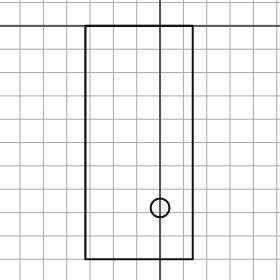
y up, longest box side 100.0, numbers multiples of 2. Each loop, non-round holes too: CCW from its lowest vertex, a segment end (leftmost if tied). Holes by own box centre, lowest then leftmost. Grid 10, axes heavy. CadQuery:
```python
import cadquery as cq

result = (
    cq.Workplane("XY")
    .moveTo(-32.0, -100.0)
    .lineTo(14.0, -100.0)
    .lineTo(14.0, 0.0)
    .lineTo(-32.0, 0.0)
    .close()
    .moveTo(0.0, -78.0)
    .circle(4.0)
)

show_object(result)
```